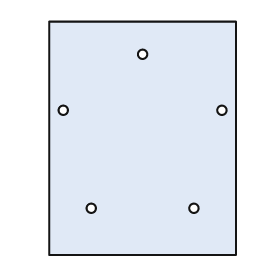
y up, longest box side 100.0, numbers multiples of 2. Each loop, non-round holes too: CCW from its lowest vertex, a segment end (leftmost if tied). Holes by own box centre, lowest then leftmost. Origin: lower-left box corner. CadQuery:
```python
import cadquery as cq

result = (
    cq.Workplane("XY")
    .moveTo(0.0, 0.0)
    .lineTo(80.0, 0.0)
    .lineTo(80.0, 100.0)
    .lineTo(0.0, 100.0)
    .close()
    .moveTo(18.0, 20.0)
    .circle(2.0)
    .moveTo(62.0, 20.0)
    .circle(2.0)
    .moveTo(6.0, 62.0)
    .circle(2.0)
    .moveTo(74.0, 62.0)
    .circle(2.0)
    .moveTo(40.0, 86.0)
    .circle(2.0)
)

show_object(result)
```